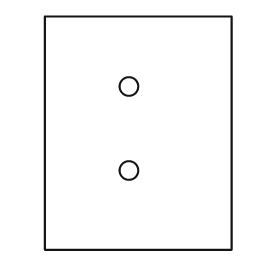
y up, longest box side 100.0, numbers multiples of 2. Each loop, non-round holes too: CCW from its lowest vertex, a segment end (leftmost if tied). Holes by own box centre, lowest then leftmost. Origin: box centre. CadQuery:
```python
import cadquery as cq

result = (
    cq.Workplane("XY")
    .moveTo(-40.0, -50.0)
    .lineTo(40.0, -50.0)
    .lineTo(40.0, 50.0)
    .lineTo(-40.0, 50.0)
    .close()
    .moveTo(-4.0, -16.0)
    .circle(4.0)
    .moveTo(-4.0, 20.0)
    .circle(4.0)
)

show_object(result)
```